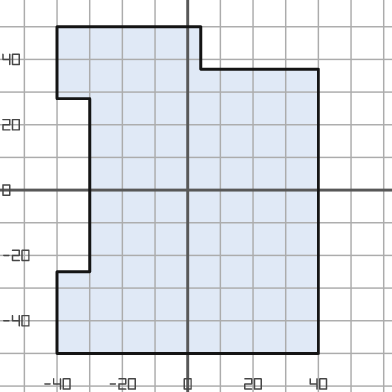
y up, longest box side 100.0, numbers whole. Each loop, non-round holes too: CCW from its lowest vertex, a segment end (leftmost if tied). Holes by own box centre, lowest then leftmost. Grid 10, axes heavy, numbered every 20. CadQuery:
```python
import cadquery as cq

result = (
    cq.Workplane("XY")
    .moveTo(-40.0, -50.0)
    .lineTo(40.0, -50.0)
    .lineTo(40.0, 37.0)
    .lineTo(4.0, 37.0)
    .lineTo(4.0, 50.0)
    .lineTo(-40.0, 50.0)
    .lineTo(-40.0, 28.0)
    .lineTo(-30.0, 28.0)
    .lineTo(-30.0, -25.0)
    .lineTo(-40.0, -25.0)
    .close()
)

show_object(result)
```